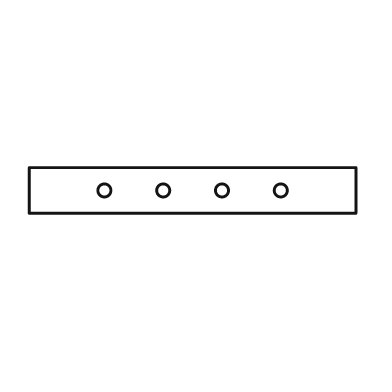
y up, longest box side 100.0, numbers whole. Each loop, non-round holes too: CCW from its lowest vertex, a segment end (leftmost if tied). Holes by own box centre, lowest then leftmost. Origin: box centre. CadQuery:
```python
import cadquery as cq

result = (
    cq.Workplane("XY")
    .moveTo(-50.0, -7.0)
    .lineTo(50.0, -7.0)
    .lineTo(50.0, 7.0)
    .lineTo(-50.0, 7.0)
    .close()
    .moveTo(-27.0, 0.0)
    .circle(2.0)
    .moveTo(-9.0, 0.0)
    .circle(2.0)
    .moveTo(9.0, 0.0)
    .circle(2.0)
    .moveTo(27.0, 0.0)
    .circle(2.0)
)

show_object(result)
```